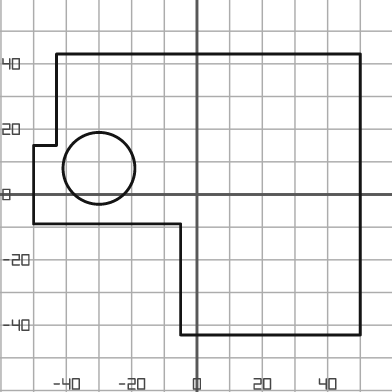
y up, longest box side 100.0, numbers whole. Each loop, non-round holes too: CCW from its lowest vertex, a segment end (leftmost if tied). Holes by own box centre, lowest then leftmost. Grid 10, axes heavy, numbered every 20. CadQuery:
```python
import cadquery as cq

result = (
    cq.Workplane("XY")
    .moveTo(-5.0, -43.0)
    .lineTo(50.0, -43.0)
    .lineTo(50.0, 43.0)
    .lineTo(-43.0, 43.0)
    .lineTo(-43.0, 15.0)
    .lineTo(-50.0, 15.0)
    .lineTo(-50.0, -9.0)
    .lineTo(-5.0, -9.0)
    .close()
    .moveTo(-30.0, 8.0)
    .circle(11.0)
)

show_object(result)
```